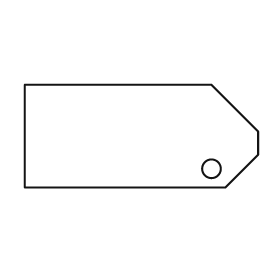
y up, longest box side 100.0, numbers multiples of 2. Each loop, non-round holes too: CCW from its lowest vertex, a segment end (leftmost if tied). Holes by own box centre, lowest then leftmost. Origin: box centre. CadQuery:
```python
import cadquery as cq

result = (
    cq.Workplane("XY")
    .moveTo(-50.0, -22.0)
    .lineTo(36.0, -22.0)
    .lineTo(50.0, -8.0)
    .lineTo(50.0, 2.0)
    .lineTo(30.0, 22.0)
    .lineTo(-50.0, 22.0)
    .close()
    .moveTo(30.0, -14.0)
    .circle(4.0)
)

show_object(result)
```